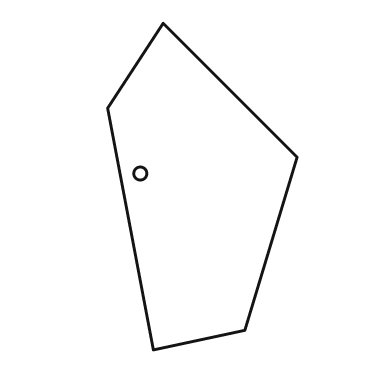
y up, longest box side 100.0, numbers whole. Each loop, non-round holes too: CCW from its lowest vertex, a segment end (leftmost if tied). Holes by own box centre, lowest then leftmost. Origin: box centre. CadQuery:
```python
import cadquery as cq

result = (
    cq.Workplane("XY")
    .moveTo(-15.0, -50.0)
    .lineTo(13.0, -44.0)
    .lineTo(29.0, 9.0)
    .lineTo(-12.0, 50.0)
    .lineTo(-29.0, 24.0)
    .close()
    .moveTo(-19.0, 4.0)
    .circle(2.0)
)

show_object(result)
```